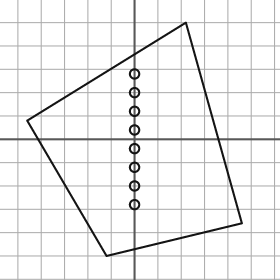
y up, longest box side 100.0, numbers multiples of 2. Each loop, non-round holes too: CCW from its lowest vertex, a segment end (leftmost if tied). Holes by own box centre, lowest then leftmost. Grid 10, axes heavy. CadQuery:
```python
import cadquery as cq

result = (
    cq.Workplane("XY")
    .moveTo(-12.0, -50.0)
    .lineTo(46.0, -36.0)
    .lineTo(22.0, 50.0)
    .lineTo(-46.0, 8.0)
    .close()
    .moveTo(0.0, -28.0)
    .circle(2.0)
    .moveTo(0.0, -20.0)
    .circle(2.0)
    .moveTo(0.0, -12.0)
    .circle(2.0)
    .moveTo(0.0, -4.0)
    .circle(2.0)
    .moveTo(0.0, 4.0)
    .circle(2.0)
    .moveTo(0.0, 12.0)
    .circle(2.0)
    .moveTo(0.0, 20.0)
    .circle(2.0)
    .moveTo(0.0, 28.0)
    .circle(2.0)
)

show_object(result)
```